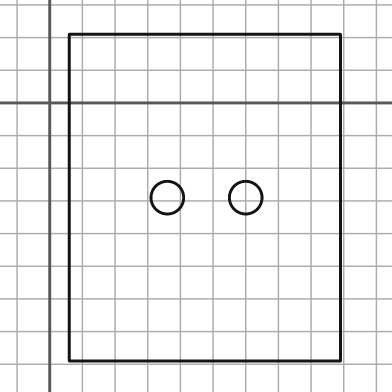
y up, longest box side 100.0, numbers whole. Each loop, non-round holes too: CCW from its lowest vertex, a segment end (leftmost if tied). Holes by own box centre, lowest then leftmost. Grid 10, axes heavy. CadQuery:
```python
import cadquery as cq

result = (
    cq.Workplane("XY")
    .moveTo(6.0, -79.0)
    .lineTo(89.0, -79.0)
    .lineTo(89.0, 21.0)
    .lineTo(6.0, 21.0)
    .close()
    .moveTo(36.0, -29.0)
    .circle(5.0)
    .moveTo(60.0, -29.0)
    .circle(5.0)
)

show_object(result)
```